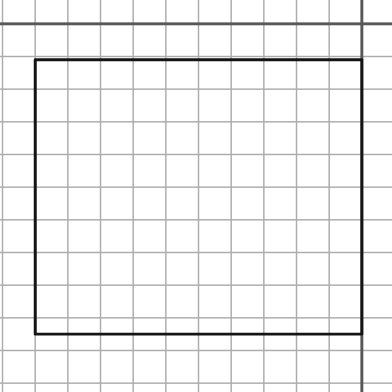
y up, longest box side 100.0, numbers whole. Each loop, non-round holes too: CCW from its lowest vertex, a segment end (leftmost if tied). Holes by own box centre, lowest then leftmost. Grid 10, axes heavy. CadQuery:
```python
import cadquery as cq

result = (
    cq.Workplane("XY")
    .moveTo(-100.0, -95.0)
    .lineTo(0.0, -95.0)
    .lineTo(0.0, -11.0)
    .lineTo(-100.0, -11.0)
    .close()
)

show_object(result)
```